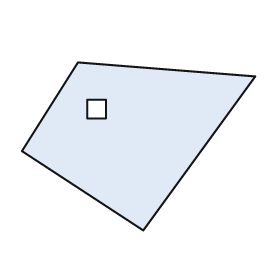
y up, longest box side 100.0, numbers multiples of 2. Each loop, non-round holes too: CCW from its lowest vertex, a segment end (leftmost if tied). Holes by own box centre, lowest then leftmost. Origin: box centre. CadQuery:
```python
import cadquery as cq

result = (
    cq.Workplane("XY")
    .moveTo(2.0, -36.0)
    .lineTo(50.0, 30.0)
    .lineTo(-26.0, 36.0)
    .lineTo(-50.0, -2.0)
    .close()
    .moveTo(-22.0, 12.0)
    .lineTo(-14.0, 12.0)
    .lineTo(-14.0, 20.0)
    .lineTo(-22.0, 20.0)
    .close()
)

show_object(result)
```